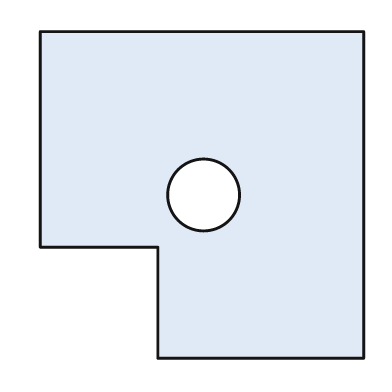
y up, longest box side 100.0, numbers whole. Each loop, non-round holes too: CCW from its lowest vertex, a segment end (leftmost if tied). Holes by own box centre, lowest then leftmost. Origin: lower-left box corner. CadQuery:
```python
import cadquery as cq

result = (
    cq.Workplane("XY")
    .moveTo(36.0, 0.0)
    .lineTo(99.0, 0.0)
    .lineTo(99.0, 100.0)
    .lineTo(0.0, 100.0)
    .lineTo(0.0, 34.0)
    .lineTo(36.0, 34.0)
    .close()
    .moveTo(50.0, 50.0)
    .circle(11.0)
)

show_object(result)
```